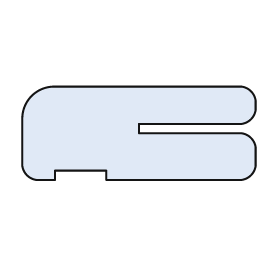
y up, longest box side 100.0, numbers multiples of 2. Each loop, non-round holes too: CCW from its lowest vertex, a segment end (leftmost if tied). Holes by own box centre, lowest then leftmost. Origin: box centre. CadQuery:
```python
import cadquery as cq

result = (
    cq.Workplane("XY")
    .moveTo(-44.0, -20.0)
    .lineTo(-36.0, -20.0)
    .lineTo(-36.0, -16.0)
    .lineTo(-14.0, -16.0)
    .lineTo(-14.0, -20.0)
    .lineTo(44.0, -20.0)
    .threePointArc((48.0, -18.0), (50.0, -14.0))
    .lineTo(50.0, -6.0)
    .threePointArc((48.0, -2.0), (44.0, 0.0))
    .lineTo(0.0, 0.0)
    .lineTo(0.0, 4.0)
    .lineTo(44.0, 4.0)
    .threePointArc((48.0, 6.0), (50.0, 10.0))
    .lineTo(50.0, 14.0)
    .threePointArc((48.0, 18.0), (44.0, 20.0))
    .lineTo(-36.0, 20.0)
    .threePointArc((-46.0, 16.0), (-50.0, 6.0))
    .lineTo(-50.0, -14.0)
    .threePointArc((-48.0, -18.0), (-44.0, -20.0))
    .close()
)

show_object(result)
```